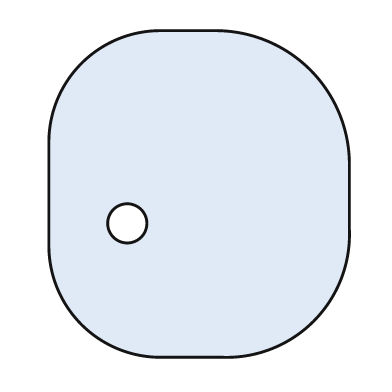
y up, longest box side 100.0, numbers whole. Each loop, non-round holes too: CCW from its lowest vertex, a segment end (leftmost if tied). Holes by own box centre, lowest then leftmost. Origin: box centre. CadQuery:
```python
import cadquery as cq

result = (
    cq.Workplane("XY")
    .moveTo(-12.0, -50.0)
    .lineTo(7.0, -50.0)
    .threePointArc((35.0, -39.0), (46.0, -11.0))
    .lineTo(46.0, 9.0)
    .threePointArc((34.0, 38.0), (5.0, 50.0))
    .lineTo(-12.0, 50.0)
    .threePointArc((-36.0, 40.0), (-46.0, 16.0))
    .lineTo(-46.0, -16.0)
    .threePointArc((-36.0, -40.0), (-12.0, -50.0))
    .close()
    .moveTo(-22.0, -9.0)
    .circle(6.0)
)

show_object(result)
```